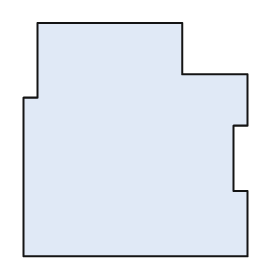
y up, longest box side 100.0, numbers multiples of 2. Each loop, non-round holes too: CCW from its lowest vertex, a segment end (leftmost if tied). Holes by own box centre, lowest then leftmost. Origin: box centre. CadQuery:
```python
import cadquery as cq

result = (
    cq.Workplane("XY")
    .moveTo(-48.0, -50.0)
    .lineTo(48.0, -50.0)
    .lineTo(48.0, -22.0)
    .lineTo(42.0, -22.0)
    .lineTo(42.0, 6.0)
    .lineTo(48.0, 6.0)
    .lineTo(48.0, 28.0)
    .lineTo(20.0, 28.0)
    .lineTo(20.0, 50.0)
    .lineTo(-42.0, 50.0)
    .lineTo(-42.0, 18.0)
    .lineTo(-48.0, 18.0)
    .close()
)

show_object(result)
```